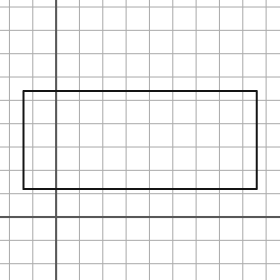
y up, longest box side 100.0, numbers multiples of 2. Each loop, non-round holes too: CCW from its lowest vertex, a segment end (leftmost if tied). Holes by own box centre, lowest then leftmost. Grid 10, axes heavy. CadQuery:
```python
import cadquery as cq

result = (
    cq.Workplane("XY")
    .moveTo(-14.0, 12.0)
    .lineTo(86.0, 12.0)
    .lineTo(86.0, 54.0)
    .lineTo(-14.0, 54.0)
    .close()
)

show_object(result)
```